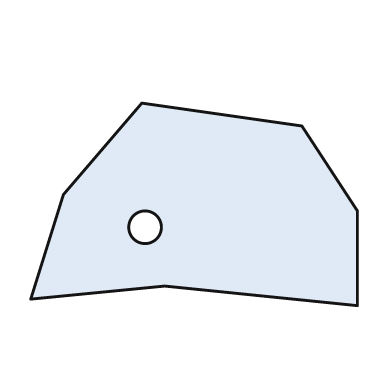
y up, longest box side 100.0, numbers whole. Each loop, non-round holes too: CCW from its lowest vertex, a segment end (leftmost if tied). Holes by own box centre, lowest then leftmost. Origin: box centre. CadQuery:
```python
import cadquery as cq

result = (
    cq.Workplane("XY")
    .moveTo(50.0, -31.0)
    .lineTo(50.0, -2.0)
    .lineTo(33.0, 24.0)
    .lineTo(-16.0, 31.0)
    .lineTo(-40.0, 3.0)
    .lineTo(-50.0, -29.0)
    .lineTo(-9.0, -25.0)
    .close()
    .moveTo(-15.0, -7.0)
    .circle(5.0)
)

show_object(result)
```